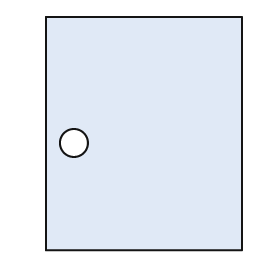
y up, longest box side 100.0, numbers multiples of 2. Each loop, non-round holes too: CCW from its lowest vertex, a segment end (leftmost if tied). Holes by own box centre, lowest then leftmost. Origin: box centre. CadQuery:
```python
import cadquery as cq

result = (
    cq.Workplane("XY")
    .moveTo(-42.0, -50.0)
    .lineTo(42.0, -50.0)
    .lineTo(42.0, 50.0)
    .lineTo(-42.0, 50.0)
    .close()
    .moveTo(-30.0, -4.0)
    .circle(6.0)
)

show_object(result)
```